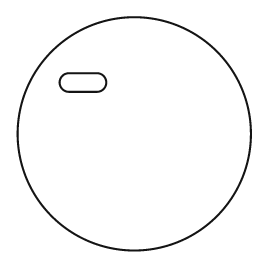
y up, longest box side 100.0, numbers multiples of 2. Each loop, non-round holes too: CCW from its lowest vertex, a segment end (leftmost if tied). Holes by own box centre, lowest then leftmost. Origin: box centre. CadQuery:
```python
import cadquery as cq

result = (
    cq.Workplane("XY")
    .moveTo(0.0, 0.0)
    .circle(50.0)
    .moveTo(-28.0, 18.0)
    .lineTo(-16.0, 18.0)
    .threePointArc((-12.0, 22.0), (-16.0, 26.0))
    .lineTo(-28.0, 26.0)
    .threePointArc((-32.0, 22.0), (-28.0, 18.0))
    .close()
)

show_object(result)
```